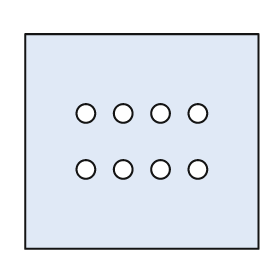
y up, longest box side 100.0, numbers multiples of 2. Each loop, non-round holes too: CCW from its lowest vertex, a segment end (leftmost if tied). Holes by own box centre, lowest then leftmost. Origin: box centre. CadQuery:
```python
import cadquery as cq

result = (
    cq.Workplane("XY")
    .moveTo(-50.0, -46.0)
    .lineTo(50.0, -46.0)
    .lineTo(50.0, 46.0)
    .lineTo(-50.0, 46.0)
    .close()
    .moveTo(-24.0, -12.0)
    .circle(4.0)
    .moveTo(-8.0, -12.0)
    .circle(4.0)
    .moveTo(8.0, -12.0)
    .circle(4.0)
    .moveTo(24.0, -12.0)
    .circle(4.0)
    .moveTo(-24.0, 12.0)
    .circle(4.0)
    .moveTo(-8.0, 12.0)
    .circle(4.0)
    .moveTo(8.0, 12.0)
    .circle(4.0)
    .moveTo(24.0, 12.0)
    .circle(4.0)
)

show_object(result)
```